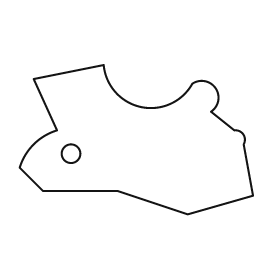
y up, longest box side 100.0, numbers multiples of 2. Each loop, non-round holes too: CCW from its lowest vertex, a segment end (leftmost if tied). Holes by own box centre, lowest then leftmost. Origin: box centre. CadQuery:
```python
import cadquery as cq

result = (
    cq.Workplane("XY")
    .moveTo(22.0, -32.0)
    .lineTo(50.0, -24.0)
    .lineTo(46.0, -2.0)
    .threePointArc((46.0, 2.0), (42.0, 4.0))
    .lineTo(32.0, 12.0)
    .threePointArc((34.0, 22.0), (24.0, 24.0))
    .threePointArc((2.0, 14.0), (-14.0, 32.0))
    .lineTo(-44.0, 26.0)
    .lineTo(-34.0, 4.0)
    .threePointArc((-44.0, -2.0), (-50.0, -12.0))
    .lineTo(-40.0, -22.0)
    .lineTo(-8.0, -22.0)
    .close()
    .moveTo(-28.0, -6.0)
    .circle(4.0)
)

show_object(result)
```